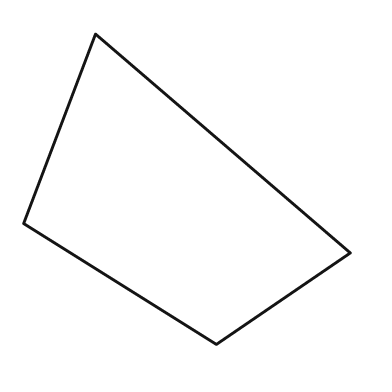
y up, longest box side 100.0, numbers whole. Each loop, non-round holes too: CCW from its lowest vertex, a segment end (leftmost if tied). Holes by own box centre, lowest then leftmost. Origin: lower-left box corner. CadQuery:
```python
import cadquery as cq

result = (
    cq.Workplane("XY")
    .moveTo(59.0, 0.0)
    .lineTo(100.0, 28.0)
    .lineTo(22.0, 95.0)
    .lineTo(0.0, 37.0)
    .close()
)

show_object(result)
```